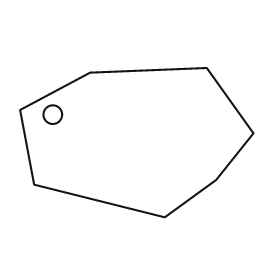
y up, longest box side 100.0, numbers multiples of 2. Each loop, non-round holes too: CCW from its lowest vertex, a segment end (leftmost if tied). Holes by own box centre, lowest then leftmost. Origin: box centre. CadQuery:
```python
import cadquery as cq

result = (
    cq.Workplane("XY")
    .moveTo(12.0, -32.0)
    .lineTo(34.0, -16.0)
    .lineTo(50.0, 4.0)
    .lineTo(30.0, 32.0)
    .lineTo(-20.0, 30.0)
    .lineTo(-50.0, 14.0)
    .lineTo(-44.0, -18.0)
    .close()
    .moveTo(-36.0, 12.0)
    .circle(4.0)
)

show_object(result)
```